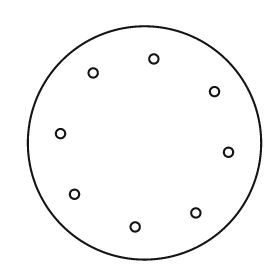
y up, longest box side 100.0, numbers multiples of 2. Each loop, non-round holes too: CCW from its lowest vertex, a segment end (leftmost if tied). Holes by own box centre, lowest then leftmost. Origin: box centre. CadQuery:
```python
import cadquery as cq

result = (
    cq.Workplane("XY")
    .moveTo(0.0, 0.0)
    .circle(50.0)
    .moveTo(-4.0, -36.0)
    .circle(2.0)
    .moveTo(22.0, -30.0)
    .circle(2.0)
    .moveTo(-30.0, -22.0)
    .circle(2.0)
    .moveTo(36.0, -4.0)
    .circle(2.0)
    .moveTo(-36.0, 4.0)
    .circle(2.0)
    .moveTo(30.0, 22.0)
    .circle(2.0)
    .moveTo(-22.0, 30.0)
    .circle(2.0)
    .moveTo(4.0, 36.0)
    .circle(2.0)
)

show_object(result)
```